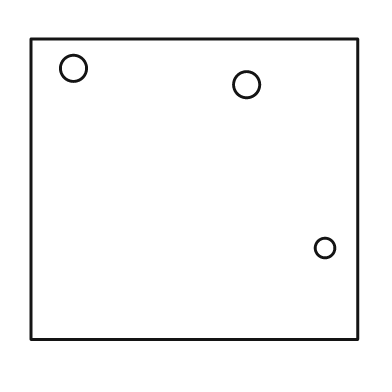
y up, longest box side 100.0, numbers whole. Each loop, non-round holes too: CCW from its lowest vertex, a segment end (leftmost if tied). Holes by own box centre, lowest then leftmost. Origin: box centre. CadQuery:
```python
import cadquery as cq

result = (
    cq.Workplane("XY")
    .moveTo(-50.0, -46.0)
    .lineTo(50.0, -46.0)
    .lineTo(50.0, 46.0)
    .lineTo(-50.0, 46.0)
    .close()
    .moveTo(40.0, -18.0)
    .circle(3.0)
    .moveTo(16.0, 32.0)
    .circle(4.0)
    .moveTo(-37.0, 37.0)
    .circle(4.0)
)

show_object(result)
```